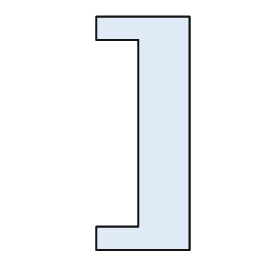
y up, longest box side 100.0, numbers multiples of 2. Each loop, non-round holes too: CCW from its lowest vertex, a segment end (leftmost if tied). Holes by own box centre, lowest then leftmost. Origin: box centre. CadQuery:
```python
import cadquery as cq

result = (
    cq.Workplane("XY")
    .moveTo(-20.0, -50.0)
    .lineTo(20.0, -50.0)
    .lineTo(20.0, 50.0)
    .lineTo(-20.0, 50.0)
    .lineTo(-20.0, 40.0)
    .lineTo(-2.0, 40.0)
    .lineTo(-2.0, -40.0)
    .lineTo(-20.0, -40.0)
    .close()
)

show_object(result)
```